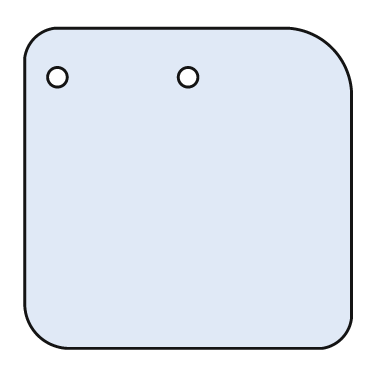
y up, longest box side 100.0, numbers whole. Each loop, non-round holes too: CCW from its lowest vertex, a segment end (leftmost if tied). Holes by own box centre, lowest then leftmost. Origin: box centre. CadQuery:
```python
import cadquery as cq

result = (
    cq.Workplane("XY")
    .moveTo(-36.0, -49.0)
    .lineTo(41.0, -49.0)
    .threePointArc((47.0, -46.0), (50.0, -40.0))
    .lineTo(50.0, 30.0)
    .threePointArc((44.0, 43.0), (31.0, 49.0))
    .lineTo(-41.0, 49.0)
    .threePointArc((-47.0, 46.0), (-50.0, 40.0))
    .lineTo(-50.0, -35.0)
    .threePointArc((-46.0, -45.0), (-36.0, -49.0))
    .close()
    .moveTo(-40.0, 34.0)
    .circle(3.0)
    .moveTo(0.0, 34.0)
    .circle(3.0)
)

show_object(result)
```